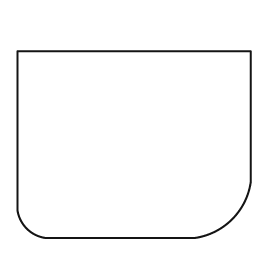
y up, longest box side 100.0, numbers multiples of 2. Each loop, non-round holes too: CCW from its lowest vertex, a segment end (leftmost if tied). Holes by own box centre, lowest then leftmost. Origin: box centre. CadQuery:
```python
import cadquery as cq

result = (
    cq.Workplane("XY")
    .moveTo(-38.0, -40.0)
    .lineTo(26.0, -40.0)
    .threePointArc((42.0, -32.0), (50.0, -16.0))
    .lineTo(50.0, 40.0)
    .lineTo(-50.0, 40.0)
    .lineTo(-50.0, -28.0)
    .threePointArc((-46.0, -36.0), (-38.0, -40.0))
    .close()
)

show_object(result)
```